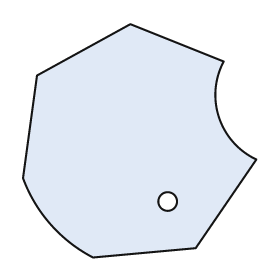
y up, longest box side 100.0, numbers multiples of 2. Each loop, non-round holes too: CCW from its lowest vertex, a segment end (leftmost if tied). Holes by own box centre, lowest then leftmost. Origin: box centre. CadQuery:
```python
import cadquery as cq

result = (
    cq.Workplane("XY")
    .moveTo(-20.0, -50.0)
    .lineTo(24.0, -46.0)
    .lineTo(50.0, -8.0)
    .threePointArc((34.0, 10.0), (36.0, 34.0))
    .lineTo(-4.0, 50.0)
    .lineTo(-44.0, 28.0)
    .lineTo(-50.0, -16.0)
    .threePointArc((-38.0, -36.0), (-20.0, -50.0))
    .close()
    .moveTo(12.0, -26.0)
    .circle(4.0)
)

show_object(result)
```